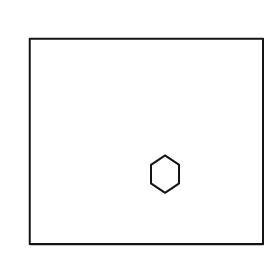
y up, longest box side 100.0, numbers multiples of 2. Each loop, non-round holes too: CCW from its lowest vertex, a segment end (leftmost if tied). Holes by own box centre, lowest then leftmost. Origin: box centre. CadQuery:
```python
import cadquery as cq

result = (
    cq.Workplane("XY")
    .moveTo(-50.0, -44.0)
    .lineTo(50.0, -44.0)
    .lineTo(50.0, 44.0)
    .lineTo(-50.0, 44.0)
    .close()
    .moveTo(8.0, -22.0)
    .lineTo(14.0, -18.0)
    .lineTo(14.0, -10.0)
    .lineTo(8.0, -6.0)
    .lineTo(2.0, -10.0)
    .lineTo(2.0, -18.0)
    .close()
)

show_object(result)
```